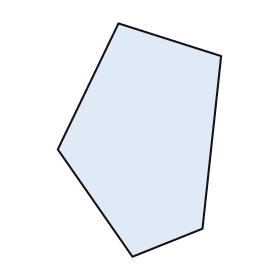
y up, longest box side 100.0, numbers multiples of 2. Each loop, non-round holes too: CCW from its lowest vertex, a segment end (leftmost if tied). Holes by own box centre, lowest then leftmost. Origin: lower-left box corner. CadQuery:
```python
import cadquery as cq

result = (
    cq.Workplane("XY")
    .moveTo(32.0, 0.0)
    .lineTo(62.0, 12.0)
    .lineTo(70.0, 86.0)
    .lineTo(26.0, 100.0)
    .lineTo(0.0, 46.0)
    .close()
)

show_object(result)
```